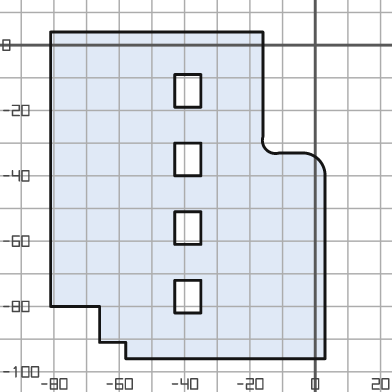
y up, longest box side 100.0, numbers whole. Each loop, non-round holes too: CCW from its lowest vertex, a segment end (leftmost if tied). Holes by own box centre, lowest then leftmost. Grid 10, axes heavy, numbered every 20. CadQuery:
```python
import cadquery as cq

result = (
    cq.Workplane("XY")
    .moveTo(-58.0, -96.0)
    .lineTo(3.0, -96.0)
    .lineTo(3.0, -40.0)
    .threePointArc((1.0, -35.0), (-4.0, -33.0))
    .lineTo(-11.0, -33.0)
    .threePointArc((-15.0, -32.0), (-16.0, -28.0))
    .lineTo(-16.0, 4.0)
    .lineTo(-81.0, 4.0)
    .lineTo(-81.0, -80.0)
    .lineTo(-66.0, -80.0)
    .lineTo(-66.0, -91.0)
    .lineTo(-58.0, -91.0)
    .close()
    .moveTo(-43.0, -82.0)
    .lineTo(-35.0, -82.0)
    .lineTo(-35.0, -72.0)
    .lineTo(-43.0, -72.0)
    .close()
    .moveTo(-43.0, -61.0)
    .lineTo(-35.0, -61.0)
    .lineTo(-35.0, -51.0)
    .lineTo(-43.0, -51.0)
    .close()
    .moveTo(-43.0, -40.0)
    .lineTo(-35.0, -40.0)
    .lineTo(-35.0, -30.0)
    .lineTo(-43.0, -30.0)
    .close()
    .moveTo(-43.0, -19.0)
    .lineTo(-35.0, -19.0)
    .lineTo(-35.0, -9.0)
    .lineTo(-43.0, -9.0)
    .close()
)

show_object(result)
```